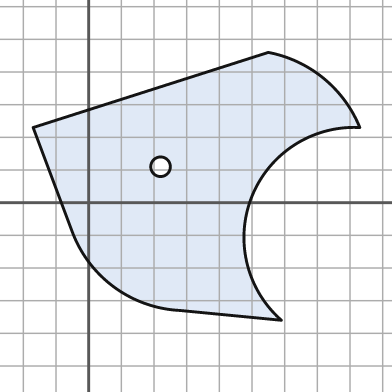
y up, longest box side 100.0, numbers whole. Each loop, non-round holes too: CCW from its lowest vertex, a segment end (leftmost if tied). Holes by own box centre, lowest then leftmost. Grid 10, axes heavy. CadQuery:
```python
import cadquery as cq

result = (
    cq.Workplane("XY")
    .moveTo(59.0, -36.0)
    .threePointArc((50.0, 2.0), (83.0, 23.0))
    .threePointArc((72.0, 38.0), (55.0, 46.0))
    .lineTo(-17.0, 23.0)
    .lineTo(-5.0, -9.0)
    .threePointArc((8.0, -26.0), (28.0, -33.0))
    .close()
    .moveTo(22.0, 11.0)
    .circle(3.0)
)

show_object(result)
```